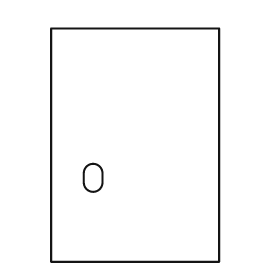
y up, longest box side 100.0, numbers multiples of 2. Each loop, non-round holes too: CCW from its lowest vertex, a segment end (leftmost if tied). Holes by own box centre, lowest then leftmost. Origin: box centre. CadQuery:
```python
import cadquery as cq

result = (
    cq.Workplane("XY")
    .moveTo(-36.0, -50.0)
    .lineTo(36.0, -50.0)
    .lineTo(36.0, 50.0)
    .lineTo(-36.0, 50.0)
    .close()
    .moveTo(-22.0, -16.0)
    .threePointArc((-18.0, -20.0), (-14.0, -16.0))
    .lineTo(-14.0, -12.0)
    .threePointArc((-18.0, -8.0), (-22.0, -12.0))
    .close()
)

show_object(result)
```